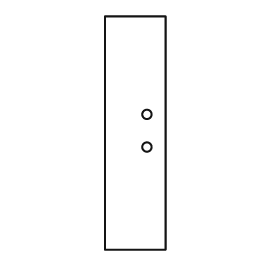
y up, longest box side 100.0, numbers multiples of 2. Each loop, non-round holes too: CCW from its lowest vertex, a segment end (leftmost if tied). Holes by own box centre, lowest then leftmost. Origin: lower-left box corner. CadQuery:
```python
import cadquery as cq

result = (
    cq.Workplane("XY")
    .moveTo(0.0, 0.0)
    .lineTo(26.0, 0.0)
    .lineTo(26.0, 100.0)
    .lineTo(0.0, 100.0)
    .close()
    .moveTo(18.0, 44.0)
    .circle(2.0)
    .moveTo(18.0, 58.0)
    .circle(2.0)
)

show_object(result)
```